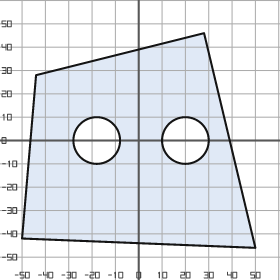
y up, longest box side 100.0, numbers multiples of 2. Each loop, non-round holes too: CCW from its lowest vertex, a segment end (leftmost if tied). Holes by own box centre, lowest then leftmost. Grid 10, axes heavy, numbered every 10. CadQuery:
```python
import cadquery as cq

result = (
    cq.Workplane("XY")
    .moveTo(50.0, -46.0)
    .lineTo(28.0, 46.0)
    .lineTo(-44.0, 28.0)
    .lineTo(-50.0, -42.0)
    .close()
    .moveTo(-18.0, 0.0)
    .circle(10.0)
    .moveTo(20.0, 0.0)
    .circle(10.0)
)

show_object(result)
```